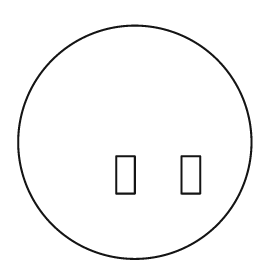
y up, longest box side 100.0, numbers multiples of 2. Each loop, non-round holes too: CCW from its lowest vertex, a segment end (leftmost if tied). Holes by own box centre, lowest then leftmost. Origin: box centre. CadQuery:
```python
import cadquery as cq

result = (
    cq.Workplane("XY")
    .moveTo(0.0, 0.0)
    .circle(50.0)
    .moveTo(-8.0, -22.0)
    .lineTo(0.0, -22.0)
    .lineTo(0.0, -6.0)
    .lineTo(-8.0, -6.0)
    .close()
    .moveTo(20.0, -22.0)
    .lineTo(28.0, -22.0)
    .lineTo(28.0, -6.0)
    .lineTo(20.0, -6.0)
    .close()
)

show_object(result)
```